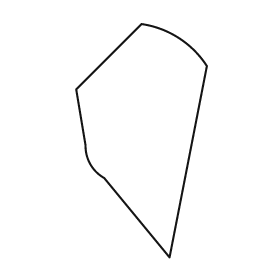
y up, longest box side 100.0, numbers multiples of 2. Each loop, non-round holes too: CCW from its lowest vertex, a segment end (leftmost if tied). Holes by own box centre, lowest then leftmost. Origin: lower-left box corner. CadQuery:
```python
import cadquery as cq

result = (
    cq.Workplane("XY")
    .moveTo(40.0, 0.0)
    .lineTo(56.0, 82.0)
    .threePointArc((44.0, 94.0), (28.0, 100.0))
    .lineTo(0.0, 72.0)
    .lineTo(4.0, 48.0)
    .threePointArc((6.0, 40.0), (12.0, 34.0))
    .close()
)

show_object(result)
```